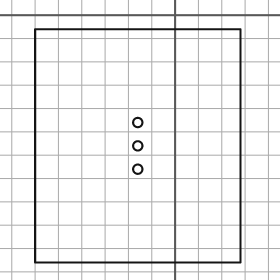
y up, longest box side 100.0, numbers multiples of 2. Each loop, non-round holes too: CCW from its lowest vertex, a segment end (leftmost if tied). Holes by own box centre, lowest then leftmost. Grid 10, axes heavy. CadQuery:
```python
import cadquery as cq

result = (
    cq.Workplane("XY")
    .moveTo(-60.0, -106.0)
    .lineTo(28.0, -106.0)
    .lineTo(28.0, -6.0)
    .lineTo(-60.0, -6.0)
    .close()
    .moveTo(-16.0, -66.0)
    .circle(2.0)
    .moveTo(-16.0, -56.0)
    .circle(2.0)
    .moveTo(-16.0, -46.0)
    .circle(2.0)
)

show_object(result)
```